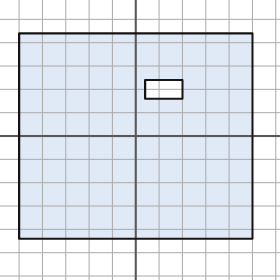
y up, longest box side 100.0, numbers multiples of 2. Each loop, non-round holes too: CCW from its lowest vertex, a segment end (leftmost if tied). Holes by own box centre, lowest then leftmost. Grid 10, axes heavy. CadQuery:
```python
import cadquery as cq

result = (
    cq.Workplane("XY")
    .moveTo(-50.0, -44.0)
    .lineTo(50.0, -44.0)
    .lineTo(50.0, 44.0)
    .lineTo(-50.0, 44.0)
    .close()
    .moveTo(4.0, 16.0)
    .lineTo(20.0, 16.0)
    .lineTo(20.0, 24.0)
    .lineTo(4.0, 24.0)
    .close()
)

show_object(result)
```